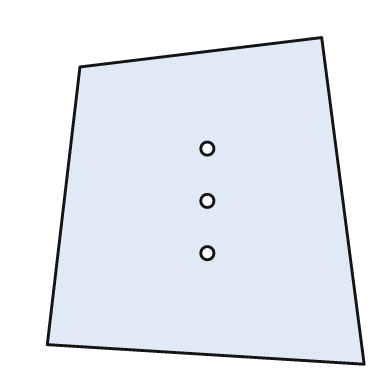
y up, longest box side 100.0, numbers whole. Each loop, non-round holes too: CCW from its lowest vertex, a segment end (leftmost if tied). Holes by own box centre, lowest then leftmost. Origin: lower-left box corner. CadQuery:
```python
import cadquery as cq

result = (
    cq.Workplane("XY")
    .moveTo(97.0, 0.0)
    .lineTo(84.0, 100.0)
    .lineTo(10.0, 91.0)
    .lineTo(0.0, 6.0)
    .close()
    .moveTo(49.0, 34.0)
    .circle(2.0)
    .moveTo(49.0, 50.0)
    .circle(2.0)
    .moveTo(49.0, 66.0)
    .circle(2.0)
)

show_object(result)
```